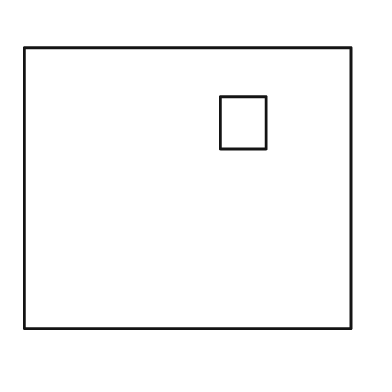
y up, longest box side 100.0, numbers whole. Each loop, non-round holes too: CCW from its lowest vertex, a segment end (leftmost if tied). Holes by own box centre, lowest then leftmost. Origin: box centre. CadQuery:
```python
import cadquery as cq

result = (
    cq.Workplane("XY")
    .moveTo(-50.0, -43.0)
    .lineTo(50.0, -43.0)
    .lineTo(50.0, 43.0)
    .lineTo(-50.0, 43.0)
    .close()
    .moveTo(10.0, 12.0)
    .lineTo(24.0, 12.0)
    .lineTo(24.0, 28.0)
    .lineTo(10.0, 28.0)
    .close()
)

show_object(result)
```